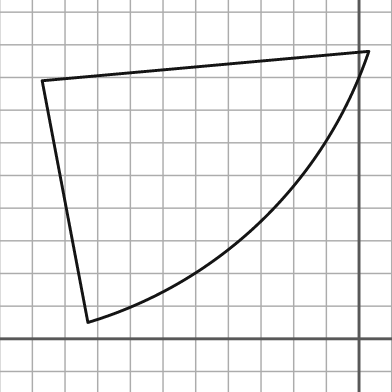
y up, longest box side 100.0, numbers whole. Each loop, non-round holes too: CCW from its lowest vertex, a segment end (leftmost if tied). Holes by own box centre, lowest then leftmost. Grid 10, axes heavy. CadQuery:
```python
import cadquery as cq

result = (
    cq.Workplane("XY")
    .moveTo(-83.0, 5.0)
    .threePointArc((-30.0, 36.0), (3.0, 88.0))
    .lineTo(-97.0, 79.0)
    .close()
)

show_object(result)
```